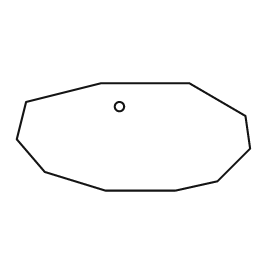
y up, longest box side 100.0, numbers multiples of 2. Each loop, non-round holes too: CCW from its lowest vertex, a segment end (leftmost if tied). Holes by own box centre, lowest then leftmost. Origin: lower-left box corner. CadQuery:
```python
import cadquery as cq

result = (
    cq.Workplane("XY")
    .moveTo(38.0, 0.0)
    .lineTo(68.0, 0.0)
    .lineTo(86.0, 4.0)
    .lineTo(100.0, 18.0)
    .lineTo(98.0, 32.0)
    .lineTo(74.0, 46.0)
    .lineTo(36.0, 46.0)
    .lineTo(4.0, 38.0)
    .lineTo(0.0, 22.0)
    .lineTo(12.0, 8.0)
    .close()
    .moveTo(44.0, 36.0)
    .circle(2.0)
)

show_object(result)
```